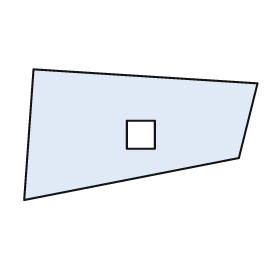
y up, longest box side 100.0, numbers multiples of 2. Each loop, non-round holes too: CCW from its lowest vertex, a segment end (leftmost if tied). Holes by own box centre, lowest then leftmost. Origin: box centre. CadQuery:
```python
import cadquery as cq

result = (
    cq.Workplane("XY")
    .moveTo(-50.0, -28.0)
    .lineTo(42.0, -10.0)
    .lineTo(50.0, 22.0)
    .lineTo(-46.0, 28.0)
    .close()
    .moveTo(-6.0, -6.0)
    .lineTo(6.0, -6.0)
    .lineTo(6.0, 6.0)
    .lineTo(-6.0, 6.0)
    .close()
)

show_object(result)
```